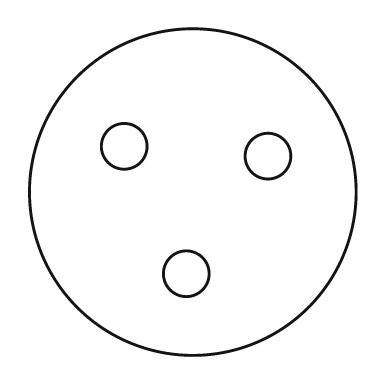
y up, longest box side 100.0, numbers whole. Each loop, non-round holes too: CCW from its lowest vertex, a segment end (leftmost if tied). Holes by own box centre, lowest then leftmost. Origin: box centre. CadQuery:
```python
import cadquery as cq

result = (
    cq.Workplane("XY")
    .moveTo(0.0, 0.0)
    .circle(50.0)
    .moveTo(-2.0, -25.0)
    .circle(7.0)
    .moveTo(23.0, 11.0)
    .circle(7.0)
    .moveTo(-21.0, 14.0)
    .circle(7.0)
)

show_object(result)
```